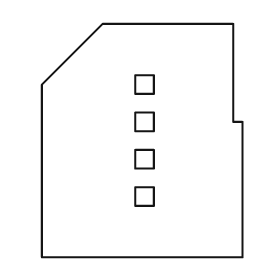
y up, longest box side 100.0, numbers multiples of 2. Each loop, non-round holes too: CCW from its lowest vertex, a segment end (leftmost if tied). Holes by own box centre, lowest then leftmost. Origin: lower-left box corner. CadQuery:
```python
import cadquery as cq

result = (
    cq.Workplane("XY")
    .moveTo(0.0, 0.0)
    .lineTo(86.0, 0.0)
    .lineTo(86.0, 58.0)
    .lineTo(82.0, 58.0)
    .lineTo(82.0, 100.0)
    .lineTo(26.0, 100.0)
    .lineTo(0.0, 74.0)
    .close()
    .moveTo(40.0, 22.0)
    .lineTo(48.0, 22.0)
    .lineTo(48.0, 30.0)
    .lineTo(40.0, 30.0)
    .close()
    .moveTo(40.0, 38.0)
    .lineTo(48.0, 38.0)
    .lineTo(48.0, 46.0)
    .lineTo(40.0, 46.0)
    .close()
    .moveTo(40.0, 54.0)
    .lineTo(48.0, 54.0)
    .lineTo(48.0, 62.0)
    .lineTo(40.0, 62.0)
    .close()
    .moveTo(40.0, 70.0)
    .lineTo(48.0, 70.0)
    .lineTo(48.0, 78.0)
    .lineTo(40.0, 78.0)
    .close()
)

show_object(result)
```